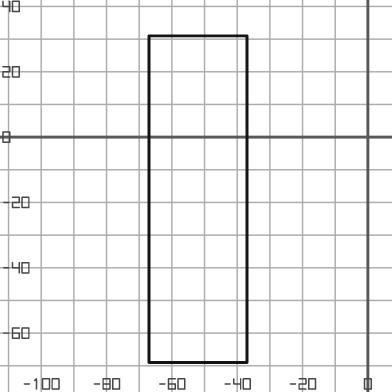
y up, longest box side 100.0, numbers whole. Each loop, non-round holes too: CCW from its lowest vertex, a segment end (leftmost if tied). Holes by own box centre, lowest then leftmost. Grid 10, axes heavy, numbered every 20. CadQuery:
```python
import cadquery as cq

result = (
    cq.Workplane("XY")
    .moveTo(-67.0, -69.0)
    .lineTo(-37.0, -69.0)
    .lineTo(-37.0, 31.0)
    .lineTo(-67.0, 31.0)
    .close()
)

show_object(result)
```